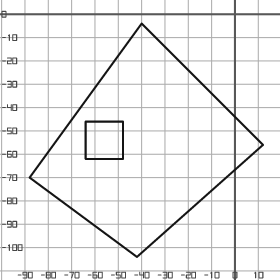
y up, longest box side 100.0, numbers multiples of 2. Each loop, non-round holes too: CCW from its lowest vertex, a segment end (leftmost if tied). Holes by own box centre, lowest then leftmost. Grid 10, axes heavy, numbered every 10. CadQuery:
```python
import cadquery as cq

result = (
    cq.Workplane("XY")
    .moveTo(-42.0, -104.0)
    .lineTo(12.0, -56.0)
    .lineTo(-40.0, -4.0)
    .lineTo(-88.0, -70.0)
    .close()
    .moveTo(-64.0, -62.0)
    .lineTo(-48.0, -62.0)
    .lineTo(-48.0, -46.0)
    .lineTo(-64.0, -46.0)
    .close()
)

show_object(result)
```